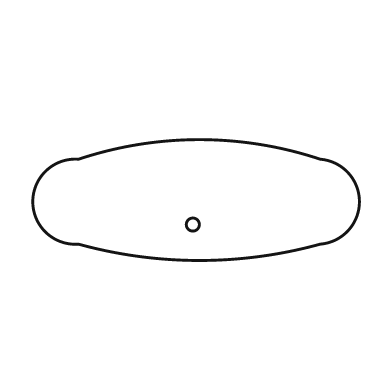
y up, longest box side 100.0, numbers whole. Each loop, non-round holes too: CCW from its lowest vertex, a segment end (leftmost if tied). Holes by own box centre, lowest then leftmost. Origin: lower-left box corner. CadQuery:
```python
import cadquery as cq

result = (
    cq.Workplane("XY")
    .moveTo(14.0, 5.0)
    .threePointArc((51.0, 0.0), (88.0, 5.0))
    .threePointArc((100.0, 18.0), (88.0, 31.0))
    .threePointArc((51.0, 37.0), (14.0, 31.0))
    .threePointArc((0.0, 18.0), (14.0, 5.0))
    .close()
    .moveTo(49.0, 11.0)
    .circle(2.0)
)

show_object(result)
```